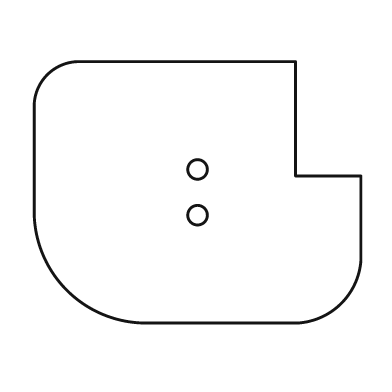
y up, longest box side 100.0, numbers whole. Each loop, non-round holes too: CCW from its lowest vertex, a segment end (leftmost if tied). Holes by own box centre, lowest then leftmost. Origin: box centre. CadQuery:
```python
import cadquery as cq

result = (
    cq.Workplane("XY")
    .moveTo(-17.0, -40.0)
    .lineTo(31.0, -40.0)
    .threePointArc((44.0, -34.0), (50.0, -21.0))
    .lineTo(50.0, 5.0)
    .lineTo(30.0, 5.0)
    .lineTo(30.0, 40.0)
    .lineTo(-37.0, 40.0)
    .threePointArc((-46.0, 36.0), (-50.0, 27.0))
    .lineTo(-50.0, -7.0)
    .threePointArc((-40.0, -30.0), (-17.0, -40.0))
    .close()
    .moveTo(0.0, -7.0)
    .circle(3.0)
    .moveTo(0.0, 7.0)
    .circle(3.0)
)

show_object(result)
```